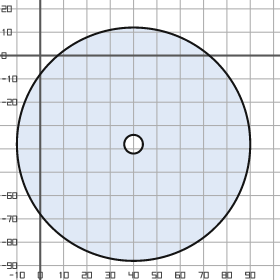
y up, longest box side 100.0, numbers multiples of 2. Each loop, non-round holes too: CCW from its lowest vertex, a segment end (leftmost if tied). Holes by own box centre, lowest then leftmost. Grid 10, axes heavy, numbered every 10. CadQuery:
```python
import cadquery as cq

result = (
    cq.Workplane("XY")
    .moveTo(40.0, -38.0)
    .circle(50.0)
    .moveTo(40.0, -38.0)
    .circle(4.0)
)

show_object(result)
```